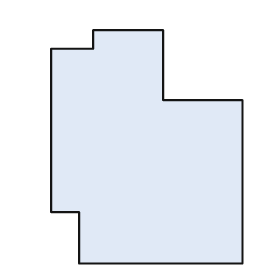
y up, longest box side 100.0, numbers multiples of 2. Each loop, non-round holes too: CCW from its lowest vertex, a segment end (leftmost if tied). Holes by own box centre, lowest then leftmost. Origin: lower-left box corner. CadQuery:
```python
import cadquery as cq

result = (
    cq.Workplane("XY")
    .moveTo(12.0, 0.0)
    .lineTo(82.0, 0.0)
    .lineTo(82.0, 70.0)
    .lineTo(48.0, 70.0)
    .lineTo(48.0, 100.0)
    .lineTo(18.0, 100.0)
    .lineTo(18.0, 92.0)
    .lineTo(0.0, 92.0)
    .lineTo(0.0, 22.0)
    .lineTo(12.0, 22.0)
    .close()
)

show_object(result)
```